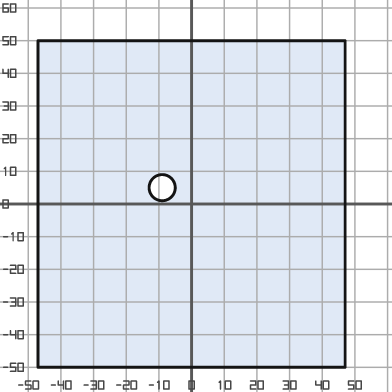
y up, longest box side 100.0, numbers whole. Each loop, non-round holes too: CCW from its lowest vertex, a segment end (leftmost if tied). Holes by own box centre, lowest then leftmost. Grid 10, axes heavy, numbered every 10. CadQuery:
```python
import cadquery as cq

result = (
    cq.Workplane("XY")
    .moveTo(-47.0, -50.0)
    .lineTo(47.0, -50.0)
    .lineTo(47.0, 50.0)
    .lineTo(-47.0, 50.0)
    .close()
    .moveTo(-9.0, 5.0)
    .circle(4.0)
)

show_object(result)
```